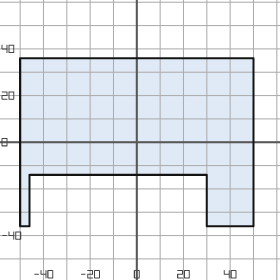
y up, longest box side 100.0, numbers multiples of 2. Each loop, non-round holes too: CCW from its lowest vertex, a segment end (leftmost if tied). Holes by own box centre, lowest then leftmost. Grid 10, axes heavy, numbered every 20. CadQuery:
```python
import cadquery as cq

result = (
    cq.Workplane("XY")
    .moveTo(-50.0, -36.0)
    .lineTo(-46.0, -36.0)
    .lineTo(-46.0, -14.0)
    .lineTo(30.0, -14.0)
    .lineTo(30.0, -36.0)
    .lineTo(50.0, -36.0)
    .lineTo(50.0, 36.0)
    .lineTo(-50.0, 36.0)
    .close()
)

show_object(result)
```